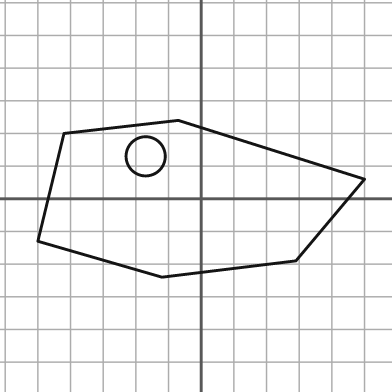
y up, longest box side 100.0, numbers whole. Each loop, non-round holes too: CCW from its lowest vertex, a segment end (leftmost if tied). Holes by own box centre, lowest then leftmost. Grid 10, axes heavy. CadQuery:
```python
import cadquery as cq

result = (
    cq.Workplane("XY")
    .moveTo(-12.0, -24.0)
    .lineTo(29.0, -19.0)
    .lineTo(50.0, 6.0)
    .lineTo(-7.0, 24.0)
    .lineTo(-42.0, 20.0)
    .lineTo(-50.0, -13.0)
    .close()
    .moveTo(-17.0, 13.0)
    .circle(6.0)
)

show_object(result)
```